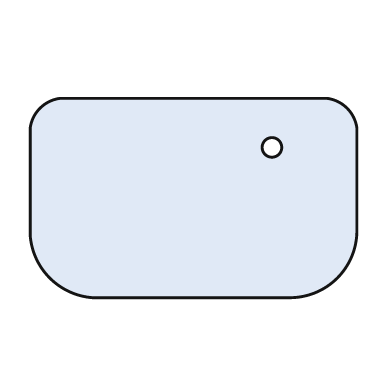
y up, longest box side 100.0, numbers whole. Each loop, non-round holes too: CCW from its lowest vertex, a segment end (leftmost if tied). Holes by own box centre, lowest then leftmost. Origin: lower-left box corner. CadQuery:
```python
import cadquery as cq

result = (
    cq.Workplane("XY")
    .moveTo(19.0, 0.0)
    .lineTo(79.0, 0.0)
    .threePointArc((94.0, 6.0), (100.0, 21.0))
    .lineTo(100.0, 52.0)
    .threePointArc((97.0, 58.0), (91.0, 61.0))
    .lineTo(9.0, 61.0)
    .threePointArc((3.0, 58.0), (0.0, 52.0))
    .lineTo(0.0, 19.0)
    .threePointArc((6.0, 6.0), (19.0, 0.0))
    .close()
    .moveTo(74.0, 46.0)
    .circle(3.0)
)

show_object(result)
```